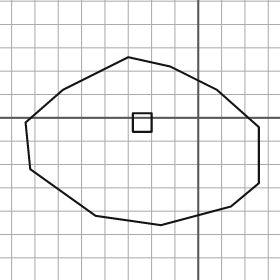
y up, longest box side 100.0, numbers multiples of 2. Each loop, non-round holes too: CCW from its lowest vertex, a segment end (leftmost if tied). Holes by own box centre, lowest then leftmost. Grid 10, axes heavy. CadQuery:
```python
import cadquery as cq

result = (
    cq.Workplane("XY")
    .moveTo(-16.0, -46.0)
    .lineTo(14.0, -38.0)
    .lineTo(26.0, -28.0)
    .lineTo(26.0, -4.0)
    .lineTo(8.0, 12.0)
    .lineTo(-12.0, 22.0)
    .lineTo(-30.0, 26.0)
    .lineTo(-58.0, 12.0)
    .lineTo(-74.0, -2.0)
    .lineTo(-72.0, -22.0)
    .lineTo(-44.0, -42.0)
    .close()
    .moveTo(-28.0, -6.0)
    .lineTo(-20.0, -6.0)
    .lineTo(-20.0, 2.0)
    .lineTo(-28.0, 2.0)
    .close()
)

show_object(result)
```